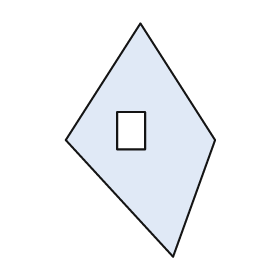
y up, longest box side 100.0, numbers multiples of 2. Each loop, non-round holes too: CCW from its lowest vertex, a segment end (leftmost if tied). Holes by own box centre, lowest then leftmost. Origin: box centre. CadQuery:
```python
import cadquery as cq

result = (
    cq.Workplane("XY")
    .moveTo(14.0, -50.0)
    .lineTo(32.0, 0.0)
    .lineTo(0.0, 50.0)
    .lineTo(-32.0, 0.0)
    .close()
    .moveTo(-10.0, -4.0)
    .lineTo(2.0, -4.0)
    .lineTo(2.0, 12.0)
    .lineTo(-10.0, 12.0)
    .close()
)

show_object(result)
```